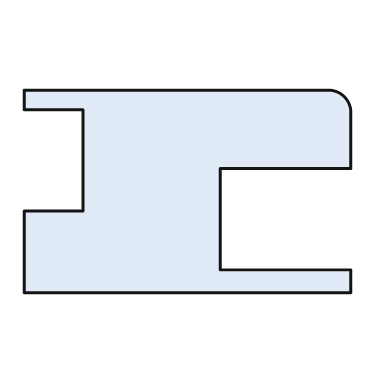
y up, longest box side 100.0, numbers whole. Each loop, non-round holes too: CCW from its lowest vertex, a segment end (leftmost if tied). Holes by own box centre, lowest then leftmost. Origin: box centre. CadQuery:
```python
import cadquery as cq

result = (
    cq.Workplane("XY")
    .moveTo(-50.0, -31.0)
    .lineTo(50.0, -31.0)
    .lineTo(50.0, -24.0)
    .lineTo(10.0, -24.0)
    .lineTo(10.0, 7.0)
    .lineTo(50.0, 7.0)
    .lineTo(50.0, 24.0)
    .threePointArc((48.0, 29.0), (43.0, 31.0))
    .lineTo(-50.0, 31.0)
    .lineTo(-50.0, 25.0)
    .lineTo(-32.0, 25.0)
    .lineTo(-32.0, -6.0)
    .lineTo(-50.0, -6.0)
    .close()
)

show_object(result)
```